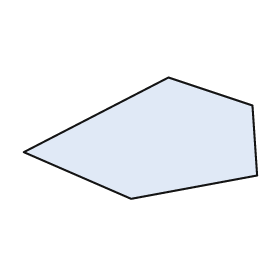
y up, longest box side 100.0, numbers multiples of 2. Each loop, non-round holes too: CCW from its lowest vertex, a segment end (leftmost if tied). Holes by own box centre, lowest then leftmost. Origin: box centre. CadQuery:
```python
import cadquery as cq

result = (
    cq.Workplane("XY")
    .moveTo(-4.0, -26.0)
    .lineTo(50.0, -16.0)
    .lineTo(48.0, 14.0)
    .lineTo(12.0, 26.0)
    .lineTo(-50.0, -6.0)
    .close()
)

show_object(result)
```